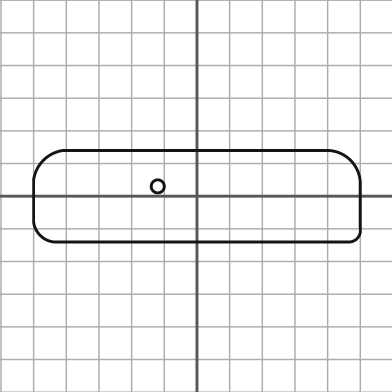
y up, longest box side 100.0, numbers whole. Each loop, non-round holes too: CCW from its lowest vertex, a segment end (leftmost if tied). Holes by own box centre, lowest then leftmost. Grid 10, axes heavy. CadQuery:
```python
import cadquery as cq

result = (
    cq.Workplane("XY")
    .moveTo(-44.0, -14.0)
    .lineTo(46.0, -14.0)
    .threePointArc((49.0, -13.0), (50.0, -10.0))
    .lineTo(50.0, 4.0)
    .threePointArc((47.0, 11.0), (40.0, 14.0))
    .lineTo(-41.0, 14.0)
    .threePointArc((-47.0, 11.0), (-50.0, 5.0))
    .lineTo(-50.0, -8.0)
    .threePointArc((-48.0, -12.0), (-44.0, -14.0))
    .close()
    .moveTo(-12.0, 3.0)
    .circle(2.0)
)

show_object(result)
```